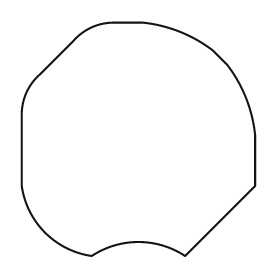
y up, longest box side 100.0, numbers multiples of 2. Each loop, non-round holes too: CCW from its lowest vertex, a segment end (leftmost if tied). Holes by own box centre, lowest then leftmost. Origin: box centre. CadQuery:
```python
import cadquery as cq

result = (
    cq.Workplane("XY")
    .moveTo(-20.0, -50.0)
    .threePointArc((0.0, -44.0), (20.0, -50.0))
    .lineTo(50.0, -20.0)
    .lineTo(50.0, 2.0)
    .threePointArc((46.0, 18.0), (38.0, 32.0))
    .lineTo(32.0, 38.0)
    .threePointArc((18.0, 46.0), (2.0, 50.0))
    .lineTo(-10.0, 50.0)
    .threePointArc((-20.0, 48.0), (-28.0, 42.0))
    .lineTo(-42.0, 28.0)
    .threePointArc((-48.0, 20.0), (-50.0, 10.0))
    .lineTo(-50.0, -20.0)
    .threePointArc((-40.0, -40.0), (-20.0, -50.0))
    .close()
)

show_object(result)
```